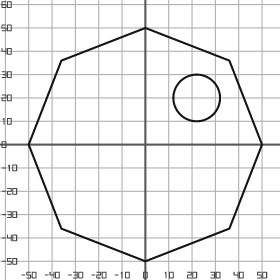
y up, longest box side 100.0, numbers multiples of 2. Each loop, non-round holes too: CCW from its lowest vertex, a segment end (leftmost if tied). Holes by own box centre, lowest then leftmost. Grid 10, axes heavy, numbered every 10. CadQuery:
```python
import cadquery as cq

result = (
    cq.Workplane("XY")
    .moveTo(0.0, -50.0)
    .lineTo(36.0, -36.0)
    .lineTo(50.0, 0.0)
    .lineTo(36.0, 36.0)
    .lineTo(0.0, 50.0)
    .lineTo(-36.0, 36.0)
    .lineTo(-50.0, 0.0)
    .lineTo(-36.0, -36.0)
    .close()
    .moveTo(22.0, 20.0)
    .circle(10.0)
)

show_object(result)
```